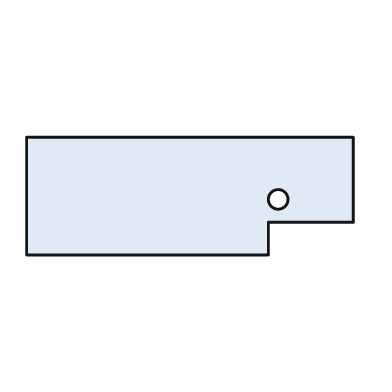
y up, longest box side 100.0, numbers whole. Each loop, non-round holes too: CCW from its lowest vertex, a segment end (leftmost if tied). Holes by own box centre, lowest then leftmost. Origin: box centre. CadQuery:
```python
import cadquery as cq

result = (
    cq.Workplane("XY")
    .moveTo(-50.0, -18.0)
    .lineTo(24.0, -18.0)
    .lineTo(24.0, -8.0)
    .lineTo(50.0, -8.0)
    .lineTo(50.0, 18.0)
    .lineTo(-50.0, 18.0)
    .close()
    .moveTo(27.0, -1.0)
    .circle(3.0)
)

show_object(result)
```